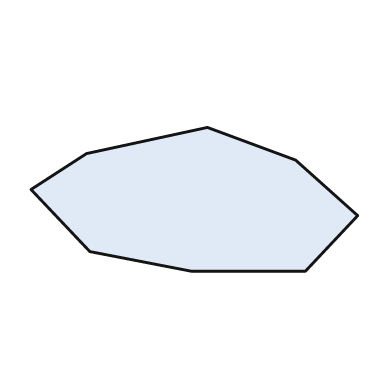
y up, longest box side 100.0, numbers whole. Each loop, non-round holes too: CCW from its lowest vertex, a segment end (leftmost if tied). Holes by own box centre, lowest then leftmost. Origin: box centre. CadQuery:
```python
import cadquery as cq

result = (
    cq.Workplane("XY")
    .moveTo(-1.0, -22.0)
    .lineTo(34.0, -22.0)
    .lineTo(50.0, -5.0)
    .lineTo(31.0, 12.0)
    .lineTo(4.0, 22.0)
    .lineTo(-33.0, 14.0)
    .lineTo(-50.0, 3.0)
    .lineTo(-32.0, -16.0)
    .close()
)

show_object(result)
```